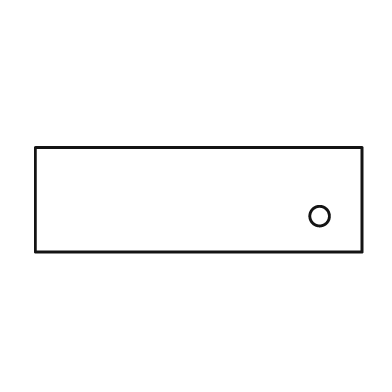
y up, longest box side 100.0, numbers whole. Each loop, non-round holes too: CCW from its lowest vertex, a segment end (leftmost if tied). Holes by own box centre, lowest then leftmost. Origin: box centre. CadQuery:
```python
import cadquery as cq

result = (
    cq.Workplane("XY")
    .moveTo(-50.0, -16.0)
    .lineTo(50.0, -16.0)
    .lineTo(50.0, 16.0)
    .lineTo(-50.0, 16.0)
    .close()
    .moveTo(37.0, -5.0)
    .circle(3.0)
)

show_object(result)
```